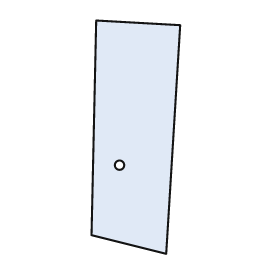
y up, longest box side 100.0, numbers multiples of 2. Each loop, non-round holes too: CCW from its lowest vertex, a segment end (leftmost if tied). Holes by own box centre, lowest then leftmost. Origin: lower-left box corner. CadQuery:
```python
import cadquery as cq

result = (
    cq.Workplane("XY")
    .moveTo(32.0, 0.0)
    .lineTo(38.0, 98.0)
    .lineTo(2.0, 100.0)
    .lineTo(0.0, 8.0)
    .close()
    .moveTo(12.0, 38.0)
    .circle(2.0)
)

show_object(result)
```